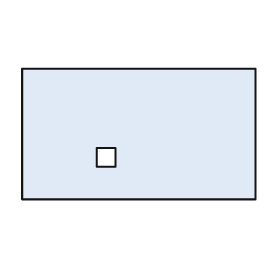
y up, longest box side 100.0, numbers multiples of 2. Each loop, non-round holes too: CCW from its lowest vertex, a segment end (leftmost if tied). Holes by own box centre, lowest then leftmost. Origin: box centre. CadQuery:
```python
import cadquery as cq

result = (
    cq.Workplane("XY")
    .moveTo(-50.0, -28.0)
    .lineTo(50.0, -28.0)
    .lineTo(50.0, 28.0)
    .lineTo(-50.0, 28.0)
    .close()
    .moveTo(-18.0, -14.0)
    .lineTo(-10.0, -14.0)
    .lineTo(-10.0, -6.0)
    .lineTo(-18.0, -6.0)
    .close()
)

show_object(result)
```